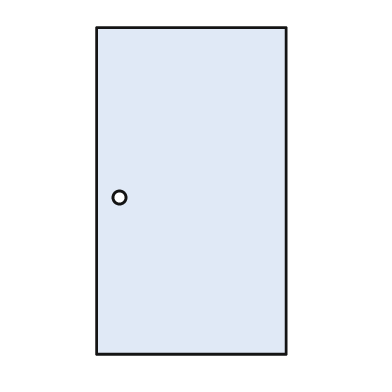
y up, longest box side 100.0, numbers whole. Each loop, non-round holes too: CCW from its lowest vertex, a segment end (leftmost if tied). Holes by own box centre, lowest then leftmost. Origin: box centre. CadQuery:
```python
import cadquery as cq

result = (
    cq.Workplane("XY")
    .moveTo(-29.0, -50.0)
    .lineTo(29.0, -50.0)
    .lineTo(29.0, 50.0)
    .lineTo(-29.0, 50.0)
    .close()
    .moveTo(-22.0, -2.0)
    .circle(2.0)
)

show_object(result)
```